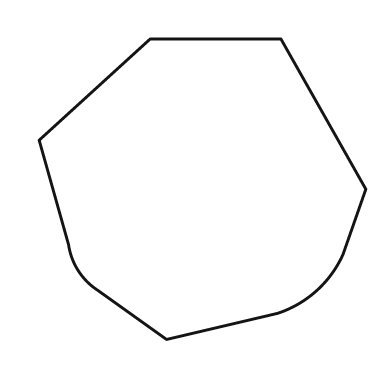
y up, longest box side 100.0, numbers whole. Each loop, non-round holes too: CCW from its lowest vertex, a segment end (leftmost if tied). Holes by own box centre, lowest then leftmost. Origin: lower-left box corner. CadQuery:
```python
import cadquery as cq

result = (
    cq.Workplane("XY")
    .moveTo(39.0, 0.0)
    .lineTo(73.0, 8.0)
    .threePointArc((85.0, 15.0), (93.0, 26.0))
    .lineTo(100.0, 46.0)
    .lineTo(74.0, 92.0)
    .lineTo(34.0, 92.0)
    .lineTo(0.0, 61.0)
    .lineTo(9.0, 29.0)
    .threePointArc((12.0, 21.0), (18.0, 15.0))
    .close()
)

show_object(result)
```